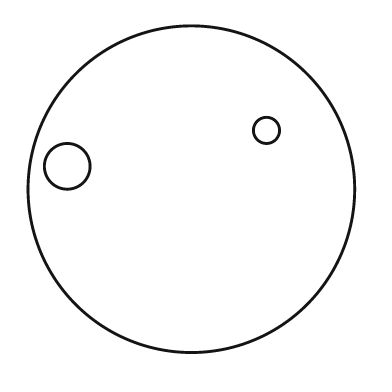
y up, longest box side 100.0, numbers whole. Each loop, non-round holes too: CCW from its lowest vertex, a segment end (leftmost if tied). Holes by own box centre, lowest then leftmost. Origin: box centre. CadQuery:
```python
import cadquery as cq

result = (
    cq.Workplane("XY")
    .moveTo(0.0, 0.0)
    .circle(50.0)
    .moveTo(-38.0, 7.0)
    .circle(7.0)
    .moveTo(23.0, 18.0)
    .circle(4.0)
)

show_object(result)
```